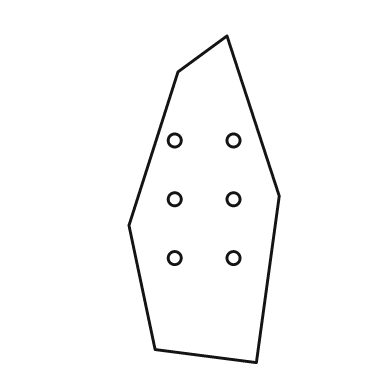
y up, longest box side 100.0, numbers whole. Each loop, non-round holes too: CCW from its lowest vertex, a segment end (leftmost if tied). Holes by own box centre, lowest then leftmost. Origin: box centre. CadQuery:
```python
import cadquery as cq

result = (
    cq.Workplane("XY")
    .moveTo(16.0, -50.0)
    .lineTo(23.0, 1.0)
    .lineTo(7.0, 50.0)
    .lineTo(-8.0, 39.0)
    .lineTo(-23.0, -8.0)
    .lineTo(-15.0, -46.0)
    .close()
    .moveTo(-9.0, -18.0)
    .circle(2.0)
    .moveTo(9.0, -18.0)
    .circle(2.0)
    .moveTo(-9.0, 0.0)
    .circle(2.0)
    .moveTo(9.0, 0.0)
    .circle(2.0)
    .moveTo(-9.0, 18.0)
    .circle(2.0)
    .moveTo(9.0, 18.0)
    .circle(2.0)
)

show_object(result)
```